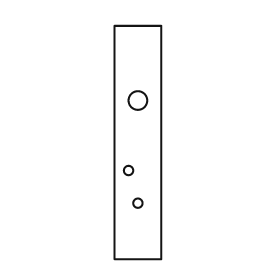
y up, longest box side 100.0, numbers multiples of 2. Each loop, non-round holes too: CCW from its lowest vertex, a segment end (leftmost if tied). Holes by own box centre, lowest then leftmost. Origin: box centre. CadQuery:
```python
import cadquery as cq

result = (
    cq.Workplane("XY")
    .moveTo(-10.0, -50.0)
    .lineTo(10.0, -50.0)
    .lineTo(10.0, 50.0)
    .lineTo(-10.0, 50.0)
    .close()
    .moveTo(0.0, -26.0)
    .circle(2.0)
    .moveTo(-4.0, -12.0)
    .circle(2.0)
    .moveTo(0.0, 18.0)
    .circle(4.0)
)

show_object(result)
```